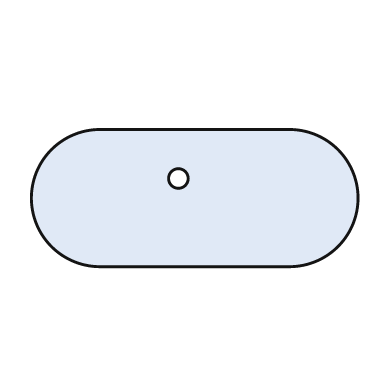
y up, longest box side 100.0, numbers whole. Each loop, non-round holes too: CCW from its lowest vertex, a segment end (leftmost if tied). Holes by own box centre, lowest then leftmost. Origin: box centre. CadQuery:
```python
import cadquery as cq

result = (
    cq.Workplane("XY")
    .moveTo(-29.0, -21.0)
    .lineTo(29.0, -21.0)
    .threePointArc((50.0, 0.0), (29.0, 21.0))
    .lineTo(-29.0, 21.0)
    .threePointArc((-50.0, 0.0), (-29.0, -21.0))
    .close()
    .moveTo(-5.0, 6.0)
    .circle(3.0)
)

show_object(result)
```